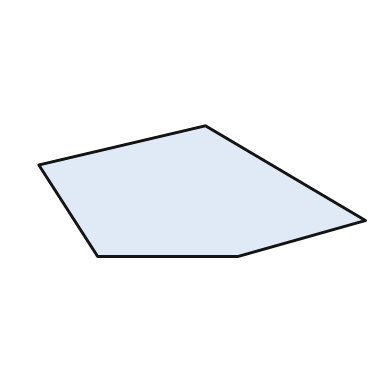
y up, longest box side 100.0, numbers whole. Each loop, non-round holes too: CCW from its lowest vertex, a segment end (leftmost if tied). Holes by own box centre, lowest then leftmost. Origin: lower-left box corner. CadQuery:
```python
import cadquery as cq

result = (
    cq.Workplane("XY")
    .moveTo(18.0, 0.0)
    .lineTo(61.0, 0.0)
    .lineTo(100.0, 11.0)
    .lineTo(51.0, 40.0)
    .lineTo(0.0, 28.0)
    .close()
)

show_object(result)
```